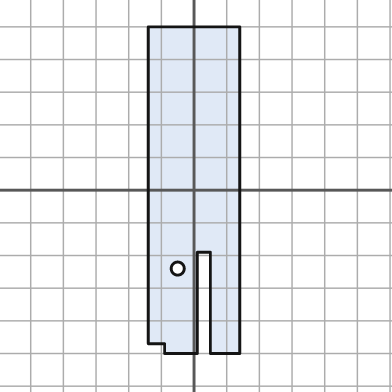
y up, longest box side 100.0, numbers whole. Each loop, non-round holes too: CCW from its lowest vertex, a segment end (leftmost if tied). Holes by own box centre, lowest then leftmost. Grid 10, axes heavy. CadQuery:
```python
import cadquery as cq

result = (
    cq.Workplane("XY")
    .moveTo(-9.0, -50.0)
    .lineTo(1.0, -50.0)
    .lineTo(1.0, -19.0)
    .lineTo(5.0, -19.0)
    .lineTo(5.0, -50.0)
    .lineTo(14.0, -50.0)
    .lineTo(14.0, 50.0)
    .lineTo(-14.0, 50.0)
    .lineTo(-14.0, -47.0)
    .lineTo(-9.0, -47.0)
    .close()
    .moveTo(-5.0, -24.0)
    .circle(2.0)
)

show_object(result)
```